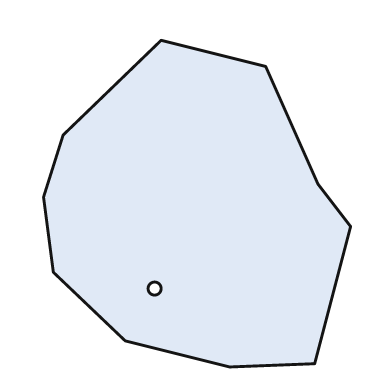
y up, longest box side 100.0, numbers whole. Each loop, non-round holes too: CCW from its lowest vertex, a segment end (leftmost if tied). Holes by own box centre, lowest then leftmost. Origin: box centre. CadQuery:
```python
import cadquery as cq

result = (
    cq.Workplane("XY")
    .moveTo(10.0, -50.0)
    .lineTo(36.0, -49.0)
    .lineTo(47.0, -7.0)
    .lineTo(37.0, 6.0)
    .lineTo(21.0, 42.0)
    .lineTo(-11.0, 50.0)
    .lineTo(-41.0, 21.0)
    .lineTo(-47.0, 2.0)
    .lineTo(-44.0, -21.0)
    .lineTo(-22.0, -42.0)
    .close()
    .moveTo(-13.0, -26.0)
    .circle(2.0)
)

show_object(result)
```